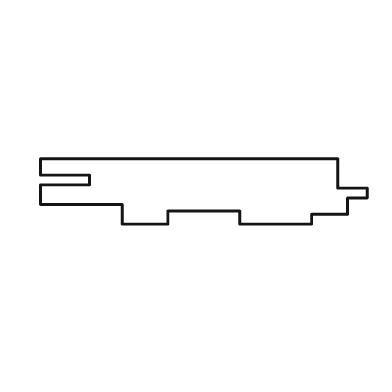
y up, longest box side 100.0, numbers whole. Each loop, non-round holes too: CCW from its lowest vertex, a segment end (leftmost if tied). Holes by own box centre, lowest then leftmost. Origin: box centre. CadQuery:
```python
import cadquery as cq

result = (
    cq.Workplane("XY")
    .moveTo(-25.0, -10.0)
    .lineTo(-11.0, -10.0)
    .lineTo(-11.0, -6.0)
    .lineTo(11.0, -6.0)
    .lineTo(11.0, -10.0)
    .lineTo(33.0, -10.0)
    .lineTo(33.0, -7.0)
    .lineTo(44.0, -7.0)
    .lineTo(44.0, -2.0)
    .lineTo(50.0, -2.0)
    .lineTo(50.0, 1.0)
    .lineTo(41.0, 1.0)
    .lineTo(41.0, 10.0)
    .lineTo(-50.0, 10.0)
    .lineTo(-50.0, 5.0)
    .lineTo(-35.0, 5.0)
    .lineTo(-35.0, 2.0)
    .lineTo(-50.0, 2.0)
    .lineTo(-50.0, -4.0)
    .lineTo(-25.0, -4.0)
    .close()
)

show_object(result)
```